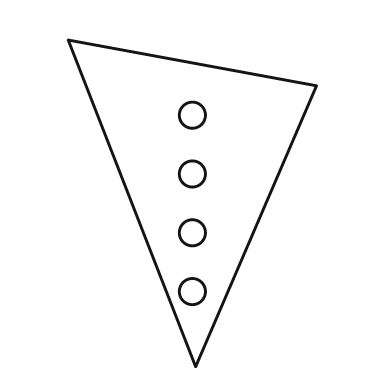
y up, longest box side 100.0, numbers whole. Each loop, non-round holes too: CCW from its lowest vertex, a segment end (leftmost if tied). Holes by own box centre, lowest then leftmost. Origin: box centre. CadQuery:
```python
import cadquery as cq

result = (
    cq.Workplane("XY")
    .moveTo(1.0, -50.0)
    .lineTo(38.0, 36.0)
    .lineTo(-38.0, 50.0)
    .close()
    .moveTo(0.0, -27.0)
    .circle(4.0)
    .moveTo(0.0, -9.0)
    .circle(4.0)
    .moveTo(0.0, 9.0)
    .circle(4.0)
    .moveTo(0.0, 27.0)
    .circle(4.0)
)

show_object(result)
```